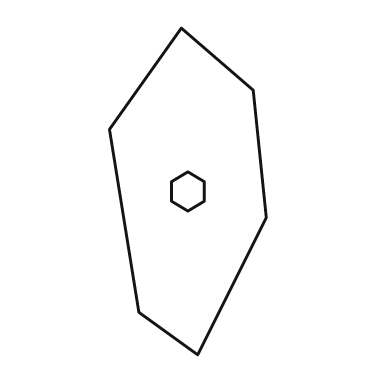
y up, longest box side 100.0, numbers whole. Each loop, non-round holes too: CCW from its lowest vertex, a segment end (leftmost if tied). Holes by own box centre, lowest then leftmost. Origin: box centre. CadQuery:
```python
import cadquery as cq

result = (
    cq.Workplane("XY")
    .moveTo(3.0, -50.0)
    .lineTo(24.0, -8.0)
    .lineTo(20.0, 31.0)
    .lineTo(-2.0, 50.0)
    .lineTo(-24.0, 19.0)
    .lineTo(-15.0, -37.0)
    .close()
    .moveTo(0.0, -6.0)
    .lineTo(5.0, -3.0)
    .lineTo(5.0, 3.0)
    .lineTo(0.0, 6.0)
    .lineTo(-5.0, 3.0)
    .lineTo(-5.0, -3.0)
    .close()
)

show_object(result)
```